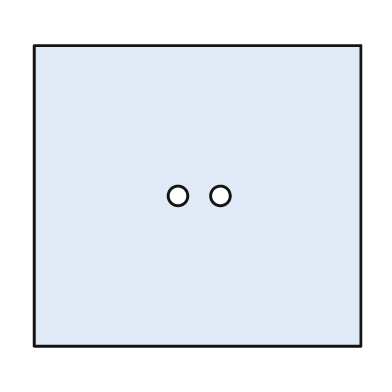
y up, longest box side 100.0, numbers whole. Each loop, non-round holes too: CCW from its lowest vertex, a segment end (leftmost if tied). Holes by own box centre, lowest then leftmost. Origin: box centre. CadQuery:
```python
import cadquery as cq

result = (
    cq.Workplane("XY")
    .moveTo(-50.0, -46.0)
    .lineTo(50.0, -46.0)
    .lineTo(50.0, 46.0)
    .lineTo(-50.0, 46.0)
    .close()
    .moveTo(-6.0, 0.0)
    .circle(3.0)
    .moveTo(7.0, 0.0)
    .circle(3.0)
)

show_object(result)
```